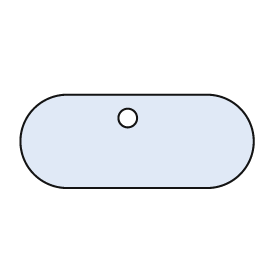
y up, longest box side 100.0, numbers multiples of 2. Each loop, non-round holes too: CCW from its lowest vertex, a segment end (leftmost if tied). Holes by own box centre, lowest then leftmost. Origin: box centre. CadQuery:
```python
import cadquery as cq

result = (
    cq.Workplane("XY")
    .moveTo(-30.0, -20.0)
    .lineTo(30.0, -20.0)
    .threePointArc((50.0, 0.0), (30.0, 20.0))
    .lineTo(-30.0, 20.0)
    .threePointArc((-50.0, 0.0), (-30.0, -20.0))
    .close()
    .moveTo(-4.0, 10.0)
    .circle(4.0)
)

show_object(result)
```